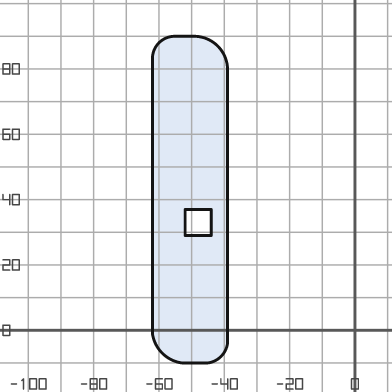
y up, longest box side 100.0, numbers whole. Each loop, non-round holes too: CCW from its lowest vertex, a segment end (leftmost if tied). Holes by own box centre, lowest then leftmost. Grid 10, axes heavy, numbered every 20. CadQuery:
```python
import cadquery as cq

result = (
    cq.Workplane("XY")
    .moveTo(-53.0, -10.0)
    .lineTo(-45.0, -10.0)
    .threePointArc((-41.0, -8.0), (-39.0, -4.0))
    .lineTo(-39.0, 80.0)
    .threePointArc((-42.0, 87.0), (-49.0, 90.0))
    .lineTo(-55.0, 90.0)
    .threePointArc((-60.0, 88.0), (-62.0, 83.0))
    .lineTo(-62.0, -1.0)
    .threePointArc((-59.0, -7.0), (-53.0, -10.0))
    .close()
    .moveTo(-52.0, 29.0)
    .lineTo(-44.0, 29.0)
    .lineTo(-44.0, 37.0)
    .lineTo(-52.0, 37.0)
    .close()
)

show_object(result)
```